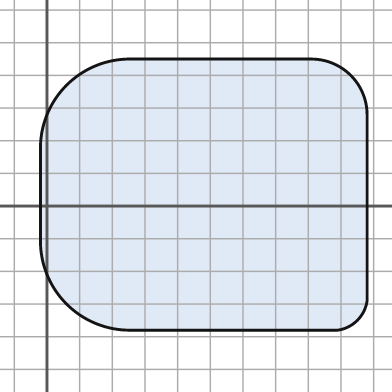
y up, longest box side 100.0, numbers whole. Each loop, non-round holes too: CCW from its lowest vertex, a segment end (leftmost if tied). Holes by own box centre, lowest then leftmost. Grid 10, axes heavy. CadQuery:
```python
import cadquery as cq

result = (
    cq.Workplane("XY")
    .moveTo(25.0, -38.0)
    .lineTo(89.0, -38.0)
    .threePointArc((95.0, -35.0), (98.0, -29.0))
    .lineTo(98.0, 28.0)
    .threePointArc((93.0, 40.0), (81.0, 45.0))
    .lineTo(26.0, 45.0)
    .threePointArc((6.0, 37.0), (-2.0, 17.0))
    .lineTo(-2.0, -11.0)
    .threePointArc((6.0, -30.0), (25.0, -38.0))
    .close()
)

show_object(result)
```